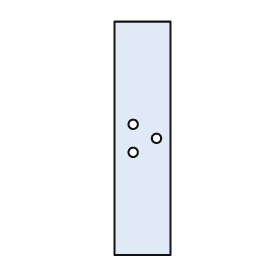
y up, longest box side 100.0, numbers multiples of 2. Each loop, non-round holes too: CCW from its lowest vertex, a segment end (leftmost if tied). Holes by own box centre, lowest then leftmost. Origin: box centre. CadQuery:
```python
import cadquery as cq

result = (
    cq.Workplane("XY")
    .moveTo(-12.0, -50.0)
    .lineTo(12.0, -50.0)
    .lineTo(12.0, 50.0)
    .lineTo(-12.0, 50.0)
    .close()
    .moveTo(-4.0, -6.0)
    .circle(2.0)
    .moveTo(6.0, 0.0)
    .circle(2.0)
    .moveTo(-4.0, 6.0)
    .circle(2.0)
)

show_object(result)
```